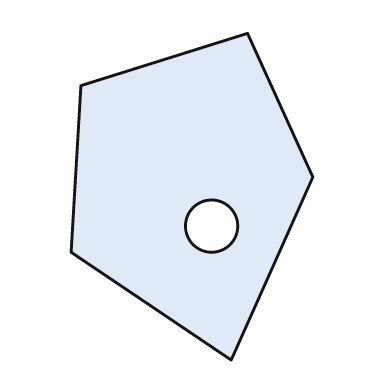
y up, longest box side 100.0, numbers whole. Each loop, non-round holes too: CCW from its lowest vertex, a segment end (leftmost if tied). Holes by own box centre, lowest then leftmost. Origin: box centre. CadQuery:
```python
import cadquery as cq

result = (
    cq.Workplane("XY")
    .moveTo(12.0, -50.0)
    .lineTo(37.0, 6.0)
    .lineTo(17.0, 50.0)
    .lineTo(-34.0, 34.0)
    .lineTo(-37.0, -17.0)
    .close()
    .moveTo(6.0, -9.0)
    .circle(8.0)
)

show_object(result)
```